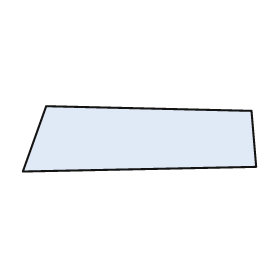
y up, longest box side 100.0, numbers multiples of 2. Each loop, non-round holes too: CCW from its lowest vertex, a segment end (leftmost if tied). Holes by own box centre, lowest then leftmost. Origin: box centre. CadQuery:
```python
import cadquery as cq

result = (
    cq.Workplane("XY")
    .moveTo(-50.0, -14.0)
    .lineTo(50.0, -12.0)
    .lineTo(48.0, 12.0)
    .lineTo(-40.0, 14.0)
    .close()
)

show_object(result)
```